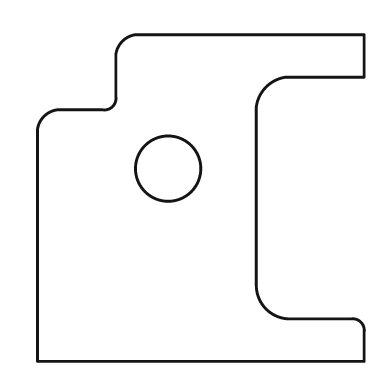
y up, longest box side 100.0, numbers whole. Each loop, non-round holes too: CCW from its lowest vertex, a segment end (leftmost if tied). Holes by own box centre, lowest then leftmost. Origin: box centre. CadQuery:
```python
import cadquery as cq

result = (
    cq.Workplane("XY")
    .moveTo(-50.0, -50.0)
    .lineTo(50.0, -50.0)
    .lineTo(50.0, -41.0)
    .threePointArc((49.0, -38.0), (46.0, -37.0))
    .lineTo(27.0, -37.0)
    .threePointArc((20.0, -34.0), (17.0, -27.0))
    .lineTo(17.0, 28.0)
    .threePointArc((20.0, 34.0), (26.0, 37.0))
    .lineTo(50.0, 37.0)
    .lineTo(50.0, 50.0)
    .lineTo(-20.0, 50.0)
    .threePointArc((-24.0, 48.0), (-26.0, 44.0))
    .lineTo(-26.0, 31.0)
    .threePointArc((-27.0, 28.0), (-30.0, 27.0))
    .lineTo(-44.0, 27.0)
    .threePointArc((-48.0, 25.0), (-50.0, 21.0))
    .close()
    .moveTo(-10.0, 9.0)
    .circle(10.0)
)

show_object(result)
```